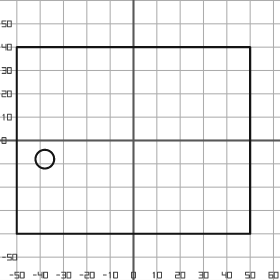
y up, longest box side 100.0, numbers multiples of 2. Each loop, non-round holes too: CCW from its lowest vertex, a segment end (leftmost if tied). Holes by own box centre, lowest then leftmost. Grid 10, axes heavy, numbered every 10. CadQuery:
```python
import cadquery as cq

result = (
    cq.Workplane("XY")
    .moveTo(-50.0, -40.0)
    .lineTo(50.0, -40.0)
    .lineTo(50.0, 40.0)
    .lineTo(-50.0, 40.0)
    .close()
    .moveTo(-38.0, -8.0)
    .circle(4.0)
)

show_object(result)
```